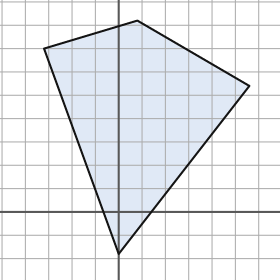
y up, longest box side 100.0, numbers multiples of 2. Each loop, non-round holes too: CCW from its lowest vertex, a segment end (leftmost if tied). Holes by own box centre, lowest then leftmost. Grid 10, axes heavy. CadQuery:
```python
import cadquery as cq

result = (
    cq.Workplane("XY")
    .moveTo(0.0, -18.0)
    .lineTo(56.0, 54.0)
    .lineTo(8.0, 82.0)
    .lineTo(-32.0, 70.0)
    .close()
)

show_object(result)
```